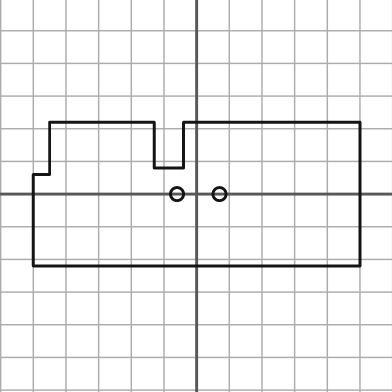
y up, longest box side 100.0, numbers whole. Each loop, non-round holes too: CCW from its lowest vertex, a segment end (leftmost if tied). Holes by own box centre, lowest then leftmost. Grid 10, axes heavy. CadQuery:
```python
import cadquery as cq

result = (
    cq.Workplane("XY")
    .moveTo(-50.0, -22.0)
    .lineTo(50.0, -22.0)
    .lineTo(50.0, 22.0)
    .lineTo(-4.0, 22.0)
    .lineTo(-4.0, 8.0)
    .lineTo(-13.0, 8.0)
    .lineTo(-13.0, 22.0)
    .lineTo(-45.0, 22.0)
    .lineTo(-45.0, 6.0)
    .lineTo(-50.0, 6.0)
    .close()
    .moveTo(-6.0, 0.0)
    .circle(2.0)
    .moveTo(7.0, 0.0)
    .circle(2.0)
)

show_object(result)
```